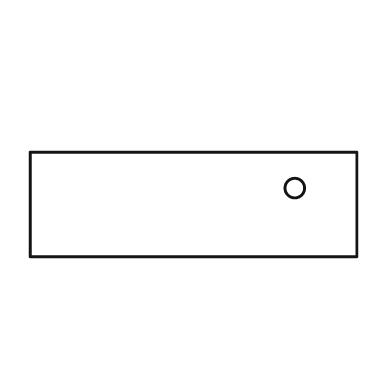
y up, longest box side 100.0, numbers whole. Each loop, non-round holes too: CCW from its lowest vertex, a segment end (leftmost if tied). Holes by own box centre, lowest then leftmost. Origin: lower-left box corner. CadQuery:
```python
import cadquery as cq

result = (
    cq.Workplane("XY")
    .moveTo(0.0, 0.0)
    .lineTo(100.0, 0.0)
    .lineTo(100.0, 32.0)
    .lineTo(0.0, 32.0)
    .close()
    .moveTo(81.0, 21.0)
    .circle(3.0)
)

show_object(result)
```